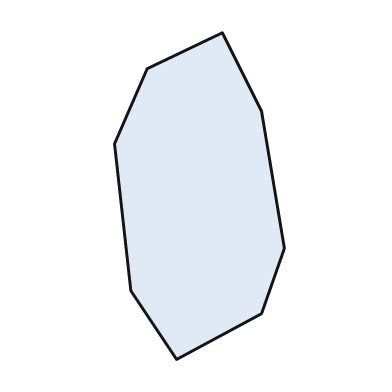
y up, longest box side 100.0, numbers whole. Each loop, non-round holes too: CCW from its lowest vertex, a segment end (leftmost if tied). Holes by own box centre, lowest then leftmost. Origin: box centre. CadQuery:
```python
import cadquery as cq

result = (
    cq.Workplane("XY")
    .moveTo(-7.0, -50.0)
    .lineTo(19.0, -36.0)
    .lineTo(26.0, -16.0)
    .lineTo(19.0, 26.0)
    .lineTo(7.0, 50.0)
    .lineTo(-16.0, 39.0)
    .lineTo(-26.0, 16.0)
    .lineTo(-21.0, -29.0)
    .close()
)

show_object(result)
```